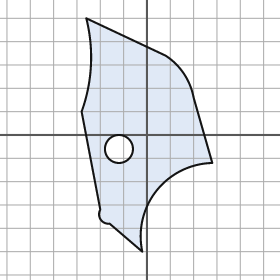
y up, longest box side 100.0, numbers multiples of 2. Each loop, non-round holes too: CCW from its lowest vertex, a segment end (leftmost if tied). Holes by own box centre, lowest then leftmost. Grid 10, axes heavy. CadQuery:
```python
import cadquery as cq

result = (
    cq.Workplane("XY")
    .moveTo(-2.0, -50.0)
    .threePointArc((4.0, -24.0), (28.0, -12.0))
    .lineTo(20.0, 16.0)
    .threePointArc((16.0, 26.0), (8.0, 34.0))
    .lineTo(-26.0, 50.0)
    .threePointArc((-24.0, 30.0), (-28.0, 10.0))
    .lineTo(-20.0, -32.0)
    .threePointArc((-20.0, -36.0), (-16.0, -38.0))
    .close()
    .moveTo(-12.0, -6.0)
    .circle(6.0)
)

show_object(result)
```